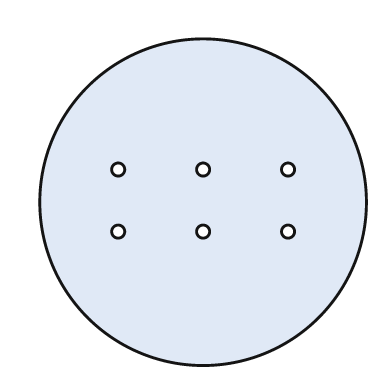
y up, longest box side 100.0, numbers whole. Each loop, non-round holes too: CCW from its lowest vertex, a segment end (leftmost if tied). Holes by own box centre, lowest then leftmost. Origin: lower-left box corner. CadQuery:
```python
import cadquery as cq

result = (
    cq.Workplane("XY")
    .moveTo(50.0, 50.0)
    .circle(50.0)
    .moveTo(24.0, 41.0)
    .circle(2.0)
    .moveTo(50.0, 41.0)
    .circle(2.0)
    .moveTo(76.0, 41.0)
    .circle(2.0)
    .moveTo(24.0, 60.0)
    .circle(2.0)
    .moveTo(50.0, 60.0)
    .circle(2.0)
    .moveTo(76.0, 60.0)
    .circle(2.0)
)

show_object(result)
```